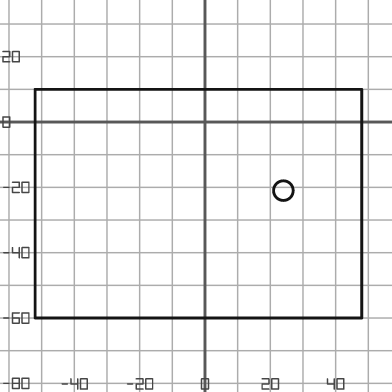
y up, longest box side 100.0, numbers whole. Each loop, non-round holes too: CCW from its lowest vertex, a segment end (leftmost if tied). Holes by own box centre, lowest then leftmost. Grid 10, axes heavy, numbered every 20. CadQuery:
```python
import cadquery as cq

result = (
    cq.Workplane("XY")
    .moveTo(-52.0, -60.0)
    .lineTo(48.0, -60.0)
    .lineTo(48.0, 10.0)
    .lineTo(-52.0, 10.0)
    .close()
    .moveTo(24.0, -21.0)
    .circle(3.0)
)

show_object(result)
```